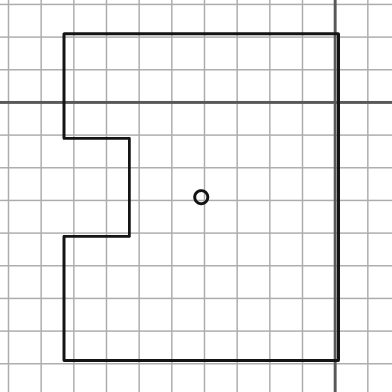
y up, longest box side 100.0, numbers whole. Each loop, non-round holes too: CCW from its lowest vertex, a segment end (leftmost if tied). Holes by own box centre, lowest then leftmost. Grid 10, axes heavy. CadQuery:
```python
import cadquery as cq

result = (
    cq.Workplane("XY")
    .moveTo(-83.0, -79.0)
    .lineTo(1.0, -79.0)
    .lineTo(1.0, 21.0)
    .lineTo(-83.0, 21.0)
    .lineTo(-83.0, -11.0)
    .lineTo(-63.0, -11.0)
    .lineTo(-63.0, -41.0)
    .lineTo(-83.0, -41.0)
    .close()
    .moveTo(-41.0, -29.0)
    .circle(2.0)
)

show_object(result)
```